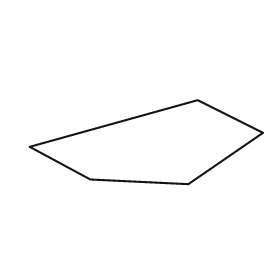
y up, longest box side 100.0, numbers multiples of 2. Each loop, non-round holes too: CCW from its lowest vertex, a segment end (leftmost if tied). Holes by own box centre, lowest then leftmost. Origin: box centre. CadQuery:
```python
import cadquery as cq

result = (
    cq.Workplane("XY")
    .moveTo(18.0, -18.0)
    .lineTo(50.0, 4.0)
    .lineTo(22.0, 18.0)
    .lineTo(-50.0, -2.0)
    .lineTo(-24.0, -16.0)
    .close()
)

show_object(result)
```